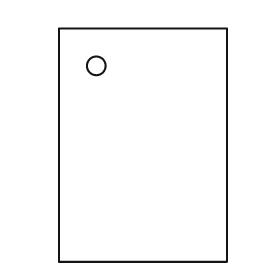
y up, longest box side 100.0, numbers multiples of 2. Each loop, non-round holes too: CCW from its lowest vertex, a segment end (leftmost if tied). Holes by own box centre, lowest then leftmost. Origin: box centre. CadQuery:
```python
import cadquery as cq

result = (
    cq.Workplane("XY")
    .moveTo(-36.0, -50.0)
    .lineTo(36.0, -50.0)
    .lineTo(36.0, 50.0)
    .lineTo(-36.0, 50.0)
    .close()
    .moveTo(-20.0, 34.0)
    .circle(4.0)
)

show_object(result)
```